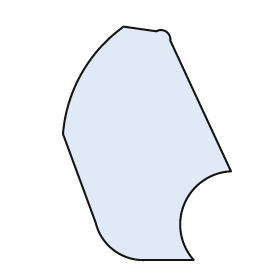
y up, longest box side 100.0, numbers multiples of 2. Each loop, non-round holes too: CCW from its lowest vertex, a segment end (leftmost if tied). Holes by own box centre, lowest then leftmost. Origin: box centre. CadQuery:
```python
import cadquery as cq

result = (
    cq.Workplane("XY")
    .moveTo(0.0, -50.0)
    .lineTo(20.0, -50.0)
    .threePointArc((16.0, -26.0), (36.0, -12.0))
    .lineTo(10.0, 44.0)
    .threePointArc((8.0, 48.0), (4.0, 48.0))
    .lineTo(-10.0, 50.0)
    .threePointArc((-28.0, 30.0), (-36.0, 4.0))
    .lineTo(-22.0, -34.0)
    .threePointArc((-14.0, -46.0), (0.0, -50.0))
    .close()
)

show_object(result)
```